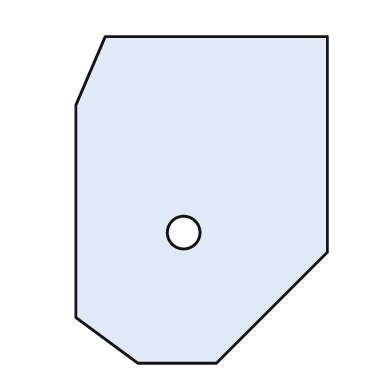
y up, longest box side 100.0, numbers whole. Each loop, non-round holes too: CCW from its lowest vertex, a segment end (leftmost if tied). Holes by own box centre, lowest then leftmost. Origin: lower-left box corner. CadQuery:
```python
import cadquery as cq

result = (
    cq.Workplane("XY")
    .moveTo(19.0, 0.0)
    .lineTo(43.0, 0.0)
    .lineTo(77.0, 34.0)
    .lineTo(77.0, 100.0)
    .lineTo(9.0, 100.0)
    .lineTo(0.0, 79.0)
    .lineTo(0.0, 14.0)
    .close()
    .moveTo(33.0, 40.0)
    .circle(5.0)
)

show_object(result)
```